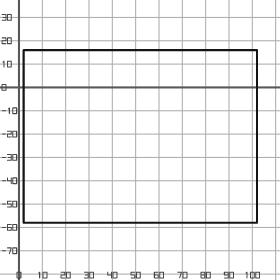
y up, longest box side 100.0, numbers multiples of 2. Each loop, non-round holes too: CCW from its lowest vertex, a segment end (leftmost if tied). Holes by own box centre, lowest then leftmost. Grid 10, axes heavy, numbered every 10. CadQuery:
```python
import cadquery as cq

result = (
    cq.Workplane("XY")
    .moveTo(2.0, -58.0)
    .lineTo(102.0, -58.0)
    .lineTo(102.0, 16.0)
    .lineTo(2.0, 16.0)
    .close()
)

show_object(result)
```